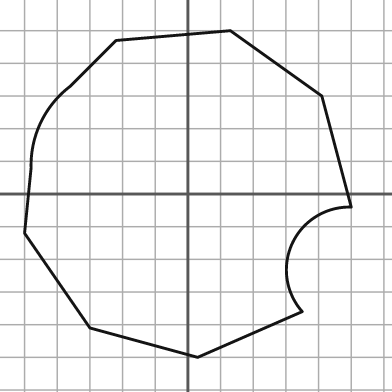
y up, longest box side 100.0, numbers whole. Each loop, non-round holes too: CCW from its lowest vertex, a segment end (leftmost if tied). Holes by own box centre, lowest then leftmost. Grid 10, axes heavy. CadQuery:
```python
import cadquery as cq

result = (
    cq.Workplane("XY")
    .moveTo(3.0, -50.0)
    .lineTo(35.0, -36.0)
    .threePointArc((32.0, -15.0), (50.0, -4.0))
    .lineTo(41.0, 30.0)
    .lineTo(13.0, 50.0)
    .lineTo(-22.0, 47.0)
    .lineTo(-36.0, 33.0)
    .threePointArc((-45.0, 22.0), (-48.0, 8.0))
    .lineTo(-50.0, -12.0)
    .lineTo(-30.0, -41.0)
    .close()
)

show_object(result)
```